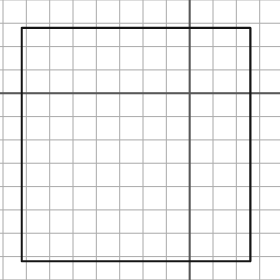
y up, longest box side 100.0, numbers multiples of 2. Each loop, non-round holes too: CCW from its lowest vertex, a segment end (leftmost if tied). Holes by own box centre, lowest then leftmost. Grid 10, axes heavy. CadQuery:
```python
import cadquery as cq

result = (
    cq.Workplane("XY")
    .moveTo(-72.0, -72.0)
    .lineTo(26.0, -72.0)
    .lineTo(26.0, 28.0)
    .lineTo(-72.0, 28.0)
    .close()
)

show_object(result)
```